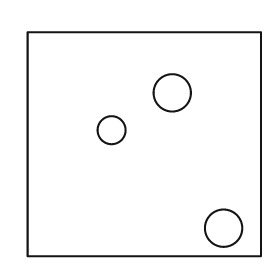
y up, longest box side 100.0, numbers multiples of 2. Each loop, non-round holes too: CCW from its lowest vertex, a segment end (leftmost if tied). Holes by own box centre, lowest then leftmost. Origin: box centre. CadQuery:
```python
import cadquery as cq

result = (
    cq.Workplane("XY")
    .moveTo(-50.0, -48.0)
    .lineTo(50.0, -48.0)
    .lineTo(50.0, 48.0)
    .lineTo(-50.0, 48.0)
    .close()
    .moveTo(34.0, -36.0)
    .circle(8.0)
    .moveTo(-14.0, 6.0)
    .circle(6.0)
    .moveTo(12.0, 22.0)
    .circle(8.0)
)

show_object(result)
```